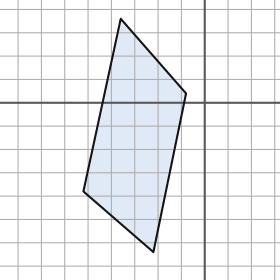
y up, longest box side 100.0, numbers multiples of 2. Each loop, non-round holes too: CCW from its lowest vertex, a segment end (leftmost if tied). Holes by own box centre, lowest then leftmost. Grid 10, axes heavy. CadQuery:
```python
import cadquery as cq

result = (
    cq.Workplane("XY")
    .moveTo(-22.0, -64.0)
    .lineTo(-8.0, 4.0)
    .lineTo(-36.0, 36.0)
    .lineTo(-52.0, -38.0)
    .close()
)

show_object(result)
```